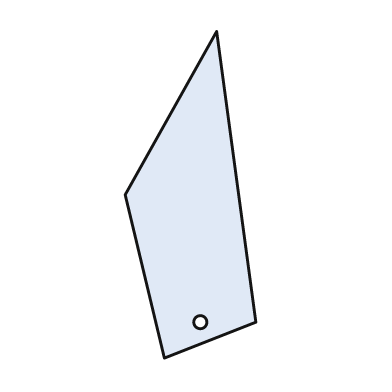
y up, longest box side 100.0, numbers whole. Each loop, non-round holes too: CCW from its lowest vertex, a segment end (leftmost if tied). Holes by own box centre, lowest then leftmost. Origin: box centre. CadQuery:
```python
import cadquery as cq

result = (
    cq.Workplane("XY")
    .moveTo(-8.0, -50.0)
    .lineTo(20.0, -39.0)
    .lineTo(8.0, 50.0)
    .lineTo(-20.0, 0.0)
    .close()
    .moveTo(3.0, -39.0)
    .circle(2.0)
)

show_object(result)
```